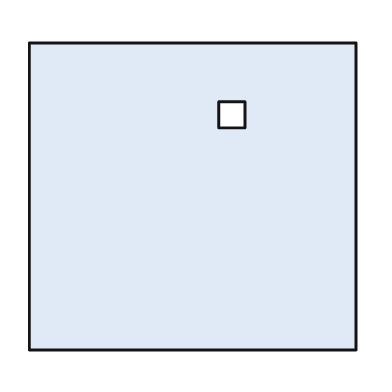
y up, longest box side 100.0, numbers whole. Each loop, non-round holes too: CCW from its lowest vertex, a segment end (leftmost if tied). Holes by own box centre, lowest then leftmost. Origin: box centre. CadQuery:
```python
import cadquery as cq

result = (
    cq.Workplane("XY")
    .moveTo(-50.0, -47.0)
    .lineTo(50.0, -47.0)
    .lineTo(50.0, 47.0)
    .lineTo(-50.0, 47.0)
    .close()
    .moveTo(8.0, 21.0)
    .lineTo(16.0, 21.0)
    .lineTo(16.0, 29.0)
    .lineTo(8.0, 29.0)
    .close()
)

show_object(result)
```